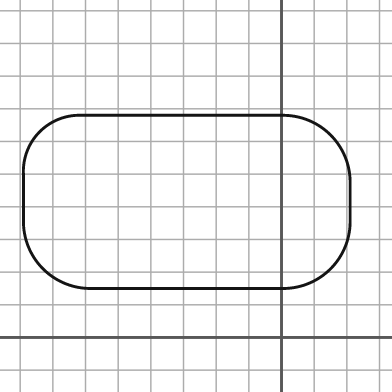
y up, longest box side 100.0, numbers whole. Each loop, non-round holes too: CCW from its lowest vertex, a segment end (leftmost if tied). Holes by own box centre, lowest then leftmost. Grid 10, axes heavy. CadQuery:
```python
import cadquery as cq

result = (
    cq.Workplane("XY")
    .moveTo(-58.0, 15.0)
    .lineTo(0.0, 15.0)
    .threePointArc((15.0, 21.0), (21.0, 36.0))
    .lineTo(21.0, 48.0)
    .threePointArc((15.0, 62.0), (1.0, 68.0))
    .lineTo(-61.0, 68.0)
    .threePointArc((-74.0, 63.0), (-79.0, 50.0))
    .lineTo(-79.0, 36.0)
    .threePointArc((-73.0, 21.0), (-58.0, 15.0))
    .close()
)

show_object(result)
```